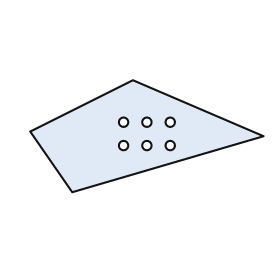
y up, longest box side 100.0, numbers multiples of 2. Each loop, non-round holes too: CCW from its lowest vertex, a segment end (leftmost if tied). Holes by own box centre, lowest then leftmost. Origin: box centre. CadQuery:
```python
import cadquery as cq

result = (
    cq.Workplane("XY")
    .moveTo(-32.0, -24.0)
    .lineTo(50.0, 0.0)
    .lineTo(-6.0, 24.0)
    .lineTo(-50.0, 2.0)
    .close()
    .moveTo(-10.0, -4.0)
    .circle(2.0)
    .moveTo(0.0, -4.0)
    .circle(2.0)
    .moveTo(10.0, -4.0)
    .circle(2.0)
    .moveTo(-10.0, 6.0)
    .circle(2.0)
    .moveTo(0.0, 6.0)
    .circle(2.0)
    .moveTo(10.0, 6.0)
    .circle(2.0)
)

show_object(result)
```